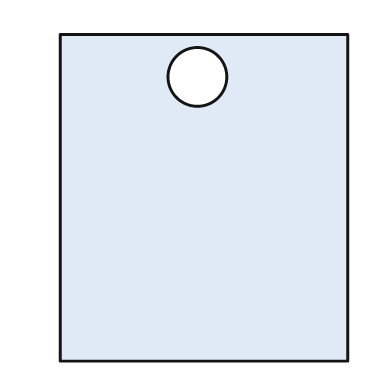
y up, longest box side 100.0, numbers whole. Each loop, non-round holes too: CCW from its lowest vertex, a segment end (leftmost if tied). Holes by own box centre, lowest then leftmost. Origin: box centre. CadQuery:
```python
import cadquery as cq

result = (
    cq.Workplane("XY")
    .moveTo(-44.0, -50.0)
    .lineTo(44.0, -50.0)
    .lineTo(44.0, 50.0)
    .lineTo(-44.0, 50.0)
    .close()
    .moveTo(-2.0, 37.0)
    .circle(9.0)
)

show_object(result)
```